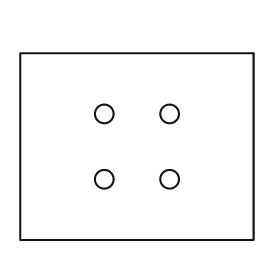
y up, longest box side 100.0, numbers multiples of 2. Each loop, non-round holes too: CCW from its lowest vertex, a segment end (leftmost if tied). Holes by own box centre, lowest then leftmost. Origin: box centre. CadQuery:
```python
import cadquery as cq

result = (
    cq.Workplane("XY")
    .moveTo(-50.0, -40.0)
    .lineTo(50.0, -40.0)
    .lineTo(50.0, 40.0)
    .lineTo(-50.0, 40.0)
    .close()
    .moveTo(-14.0, -14.0)
    .circle(4.0)
    .moveTo(14.0, -14.0)
    .circle(4.0)
    .moveTo(-14.0, 14.0)
    .circle(4.0)
    .moveTo(14.0, 14.0)
    .circle(4.0)
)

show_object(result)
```